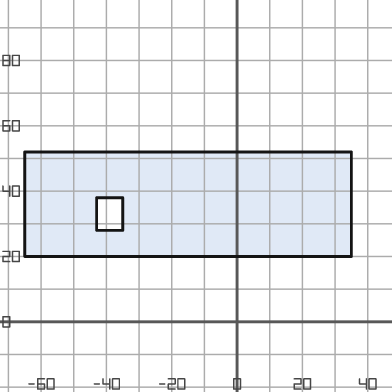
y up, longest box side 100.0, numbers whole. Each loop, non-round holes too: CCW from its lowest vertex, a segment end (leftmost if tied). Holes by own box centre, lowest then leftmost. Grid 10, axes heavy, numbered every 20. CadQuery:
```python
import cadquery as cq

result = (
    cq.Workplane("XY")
    .moveTo(-65.0, 20.0)
    .lineTo(35.0, 20.0)
    .lineTo(35.0, 52.0)
    .lineTo(-65.0, 52.0)
    .close()
    .moveTo(-43.0, 28.0)
    .lineTo(-35.0, 28.0)
    .lineTo(-35.0, 38.0)
    .lineTo(-43.0, 38.0)
    .close()
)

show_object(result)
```